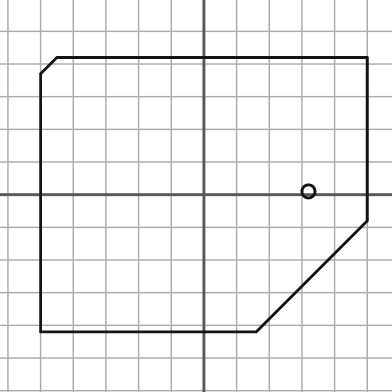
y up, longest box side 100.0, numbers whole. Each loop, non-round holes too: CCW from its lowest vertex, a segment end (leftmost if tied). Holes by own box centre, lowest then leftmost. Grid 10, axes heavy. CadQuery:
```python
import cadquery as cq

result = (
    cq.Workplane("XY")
    .moveTo(-50.0, -42.0)
    .lineTo(16.0, -42.0)
    .lineTo(50.0, -8.0)
    .lineTo(50.0, 42.0)
    .lineTo(-45.0, 42.0)
    .lineTo(-50.0, 37.0)
    .close()
    .moveTo(32.0, 1.0)
    .circle(2.0)
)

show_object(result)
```